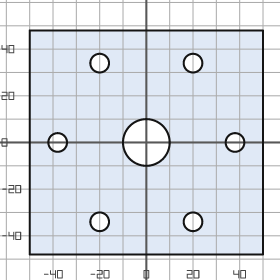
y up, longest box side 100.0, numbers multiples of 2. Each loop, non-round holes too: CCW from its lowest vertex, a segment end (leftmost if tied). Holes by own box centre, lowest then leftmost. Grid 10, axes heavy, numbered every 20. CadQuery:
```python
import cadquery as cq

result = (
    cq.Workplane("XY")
    .moveTo(-50.0, -48.0)
    .lineTo(50.0, -48.0)
    .lineTo(50.0, 48.0)
    .lineTo(-50.0, 48.0)
    .close()
    .moveTo(-20.0, -34.0)
    .circle(4.0)
    .moveTo(20.0, -34.0)
    .circle(4.0)
    .moveTo(-38.0, 0.0)
    .circle(4.0)
    .moveTo(0.0, 0.0)
    .circle(10.0)
    .moveTo(38.0, 0.0)
    .circle(4.0)
    .moveTo(-20.0, 34.0)
    .circle(4.0)
    .moveTo(20.0, 34.0)
    .circle(4.0)
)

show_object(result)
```